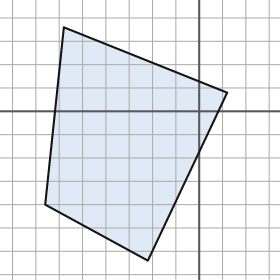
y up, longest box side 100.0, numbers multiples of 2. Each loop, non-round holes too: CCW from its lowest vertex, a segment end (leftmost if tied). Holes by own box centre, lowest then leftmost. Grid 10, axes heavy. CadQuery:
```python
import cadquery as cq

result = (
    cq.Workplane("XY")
    .moveTo(-22.0, -64.0)
    .lineTo(12.0, 8.0)
    .lineTo(-58.0, 36.0)
    .lineTo(-66.0, -40.0)
    .close()
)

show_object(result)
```